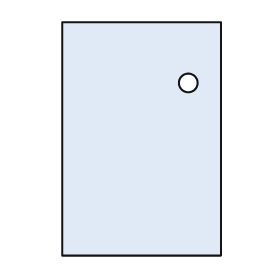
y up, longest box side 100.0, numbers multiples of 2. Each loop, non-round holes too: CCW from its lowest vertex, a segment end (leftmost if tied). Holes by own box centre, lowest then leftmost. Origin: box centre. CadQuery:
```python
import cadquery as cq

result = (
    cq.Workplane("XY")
    .moveTo(-34.0, -50.0)
    .lineTo(34.0, -50.0)
    .lineTo(34.0, 50.0)
    .lineTo(-34.0, 50.0)
    .close()
    .moveTo(20.0, 24.0)
    .circle(4.0)
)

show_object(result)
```